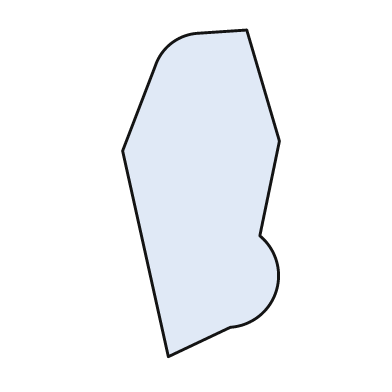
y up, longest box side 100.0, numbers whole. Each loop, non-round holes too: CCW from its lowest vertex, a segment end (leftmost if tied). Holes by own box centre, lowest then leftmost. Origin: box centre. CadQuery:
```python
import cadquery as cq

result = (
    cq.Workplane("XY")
    .moveTo(-10.0, -50.0)
    .lineTo(9.0, -41.0)
    .threePointArc((23.0, -30.0), (18.0, -13.0))
    .lineTo(24.0, 16.0)
    .lineTo(14.0, 50.0)
    .lineTo(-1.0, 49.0)
    .threePointArc((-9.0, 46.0), (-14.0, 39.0))
    .lineTo(-24.0, 13.0)
    .close()
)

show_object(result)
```